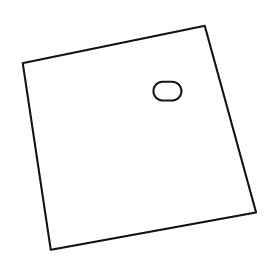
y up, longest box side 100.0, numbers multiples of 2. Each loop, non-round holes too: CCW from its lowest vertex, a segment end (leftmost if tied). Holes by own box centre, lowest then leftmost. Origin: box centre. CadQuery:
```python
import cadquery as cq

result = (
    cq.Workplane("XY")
    .moveTo(-38.0, -48.0)
    .lineTo(50.0, -32.0)
    .lineTo(28.0, 48.0)
    .lineTo(-50.0, 32.0)
    .close()
    .moveTo(10.0, 16.0)
    .lineTo(14.0, 16.0)
    .threePointArc((18.0, 20.0), (14.0, 24.0))
    .lineTo(10.0, 24.0)
    .threePointArc((6.0, 20.0), (10.0, 16.0))
    .close()
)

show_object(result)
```